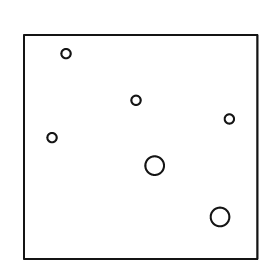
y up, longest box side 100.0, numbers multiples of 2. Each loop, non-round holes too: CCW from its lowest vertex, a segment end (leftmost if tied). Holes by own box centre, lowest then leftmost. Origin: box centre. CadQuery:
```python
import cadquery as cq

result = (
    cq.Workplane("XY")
    .moveTo(-50.0, -48.0)
    .lineTo(50.0, -48.0)
    .lineTo(50.0, 48.0)
    .lineTo(-50.0, 48.0)
    .close()
    .moveTo(34.0, -30.0)
    .circle(4.0)
    .moveTo(6.0, -8.0)
    .circle(4.0)
    .moveTo(-38.0, 4.0)
    .circle(2.0)
    .moveTo(38.0, 12.0)
    .circle(2.0)
    .moveTo(-2.0, 20.0)
    .circle(2.0)
    .moveTo(-32.0, 40.0)
    .circle(2.0)
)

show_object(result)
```